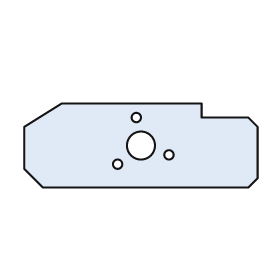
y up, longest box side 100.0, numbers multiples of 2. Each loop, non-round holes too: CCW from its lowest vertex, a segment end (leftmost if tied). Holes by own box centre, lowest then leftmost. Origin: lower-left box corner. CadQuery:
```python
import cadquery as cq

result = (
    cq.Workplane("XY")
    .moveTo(8.0, 0.0)
    .lineTo(96.0, 0.0)
    .lineTo(100.0, 4.0)
    .lineTo(100.0, 26.0)
    .lineTo(96.0, 30.0)
    .lineTo(76.0, 30.0)
    .lineTo(76.0, 36.0)
    .lineTo(16.0, 36.0)
    .lineTo(0.0, 26.0)
    .lineTo(0.0, 8.0)
    .close()
    .moveTo(40.0, 10.0)
    .circle(2.0)
    .moveTo(62.0, 14.0)
    .circle(2.0)
    .moveTo(50.0, 18.0)
    .circle(6.0)
    .moveTo(48.0, 30.0)
    .circle(2.0)
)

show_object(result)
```